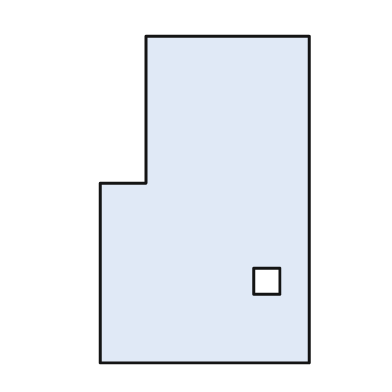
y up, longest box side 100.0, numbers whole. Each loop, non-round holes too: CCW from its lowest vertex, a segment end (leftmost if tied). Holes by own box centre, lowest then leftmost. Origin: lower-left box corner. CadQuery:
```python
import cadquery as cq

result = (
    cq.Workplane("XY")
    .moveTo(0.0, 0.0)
    .lineTo(64.0, 0.0)
    .lineTo(64.0, 100.0)
    .lineTo(14.0, 100.0)
    .lineTo(14.0, 55.0)
    .lineTo(0.0, 55.0)
    .close()
    .moveTo(47.0, 21.0)
    .lineTo(55.0, 21.0)
    .lineTo(55.0, 29.0)
    .lineTo(47.0, 29.0)
    .close()
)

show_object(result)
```